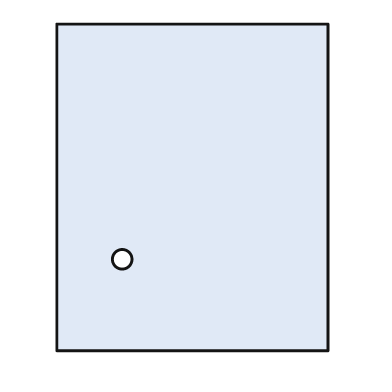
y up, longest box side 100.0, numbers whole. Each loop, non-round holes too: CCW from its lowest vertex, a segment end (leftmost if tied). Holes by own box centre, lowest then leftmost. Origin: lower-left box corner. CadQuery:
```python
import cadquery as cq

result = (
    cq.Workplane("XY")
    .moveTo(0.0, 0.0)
    .lineTo(83.0, 0.0)
    .lineTo(83.0, 100.0)
    .lineTo(0.0, 100.0)
    .close()
    .moveTo(20.0, 28.0)
    .circle(3.0)
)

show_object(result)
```